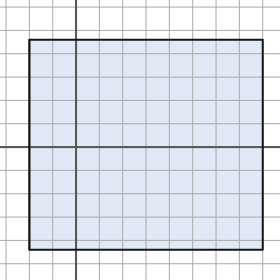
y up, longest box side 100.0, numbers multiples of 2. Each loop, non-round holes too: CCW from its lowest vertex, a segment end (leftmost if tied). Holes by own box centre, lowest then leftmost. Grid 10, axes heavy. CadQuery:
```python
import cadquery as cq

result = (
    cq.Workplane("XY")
    .moveTo(-20.0, -44.0)
    .lineTo(80.0, -44.0)
    .lineTo(80.0, 46.0)
    .lineTo(-20.0, 46.0)
    .close()
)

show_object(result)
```